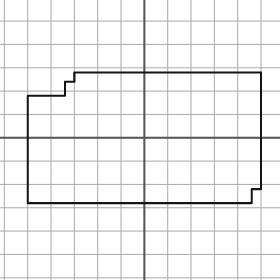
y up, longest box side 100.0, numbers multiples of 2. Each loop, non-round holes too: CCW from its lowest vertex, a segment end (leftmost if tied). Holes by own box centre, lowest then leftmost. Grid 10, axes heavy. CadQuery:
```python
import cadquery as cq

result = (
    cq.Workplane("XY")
    .moveTo(-50.0, -28.0)
    .lineTo(46.0, -28.0)
    .lineTo(46.0, -22.0)
    .lineTo(50.0, -22.0)
    .lineTo(50.0, 28.0)
    .lineTo(-30.0, 28.0)
    .lineTo(-30.0, 24.0)
    .lineTo(-34.0, 24.0)
    .lineTo(-34.0, 18.0)
    .lineTo(-50.0, 18.0)
    .close()
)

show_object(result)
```